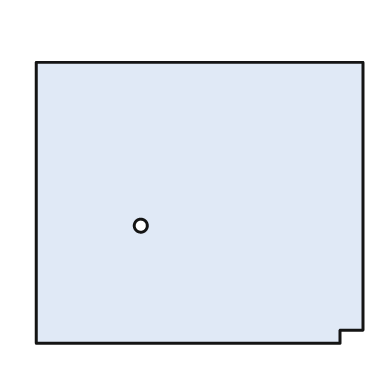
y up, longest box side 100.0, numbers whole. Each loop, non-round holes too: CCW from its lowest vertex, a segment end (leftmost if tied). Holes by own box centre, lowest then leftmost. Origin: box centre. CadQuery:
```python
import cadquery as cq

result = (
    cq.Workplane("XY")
    .moveTo(-50.0, -43.0)
    .lineTo(43.0, -43.0)
    .lineTo(43.0, -39.0)
    .lineTo(50.0, -39.0)
    .lineTo(50.0, 43.0)
    .lineTo(-50.0, 43.0)
    .close()
    .moveTo(-18.0, -7.0)
    .circle(2.0)
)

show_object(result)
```